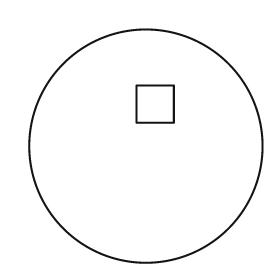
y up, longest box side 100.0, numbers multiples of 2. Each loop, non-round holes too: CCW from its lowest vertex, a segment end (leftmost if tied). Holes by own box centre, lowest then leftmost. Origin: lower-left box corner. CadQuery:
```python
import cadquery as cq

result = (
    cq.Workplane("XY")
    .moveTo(50.0, 50.0)
    .circle(50.0)
    .moveTo(46.0, 60.0)
    .lineTo(62.0, 60.0)
    .lineTo(62.0, 76.0)
    .lineTo(46.0, 76.0)
    .close()
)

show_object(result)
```